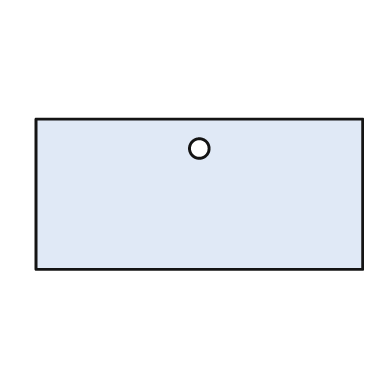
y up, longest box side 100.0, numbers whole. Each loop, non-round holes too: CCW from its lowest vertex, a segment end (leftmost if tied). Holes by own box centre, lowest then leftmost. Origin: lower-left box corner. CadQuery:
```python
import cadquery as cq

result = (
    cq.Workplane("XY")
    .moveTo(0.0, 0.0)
    .lineTo(100.0, 0.0)
    .lineTo(100.0, 46.0)
    .lineTo(0.0, 46.0)
    .close()
    .moveTo(50.0, 37.0)
    .circle(3.0)
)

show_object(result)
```